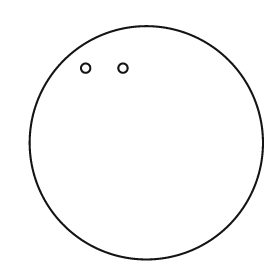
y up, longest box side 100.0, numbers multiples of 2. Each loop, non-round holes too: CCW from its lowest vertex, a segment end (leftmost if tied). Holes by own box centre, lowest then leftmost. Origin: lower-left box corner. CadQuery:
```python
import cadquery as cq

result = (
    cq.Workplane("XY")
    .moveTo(50.0, 50.0)
    .circle(50.0)
    .moveTo(24.0, 82.0)
    .circle(2.0)
    .moveTo(40.0, 82.0)
    .circle(2.0)
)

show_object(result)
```